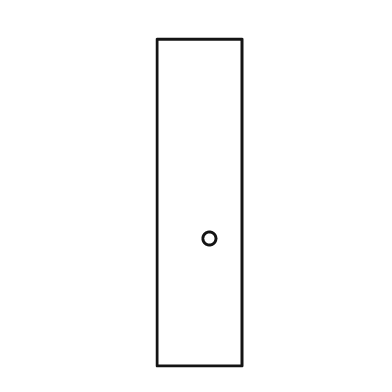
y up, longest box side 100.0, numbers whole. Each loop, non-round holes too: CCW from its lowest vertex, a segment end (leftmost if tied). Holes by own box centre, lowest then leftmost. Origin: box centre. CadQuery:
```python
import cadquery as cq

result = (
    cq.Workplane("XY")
    .moveTo(-13.0, -50.0)
    .lineTo(13.0, -50.0)
    .lineTo(13.0, 50.0)
    .lineTo(-13.0, 50.0)
    .close()
    .moveTo(3.0, -11.0)
    .circle(2.0)
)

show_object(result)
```